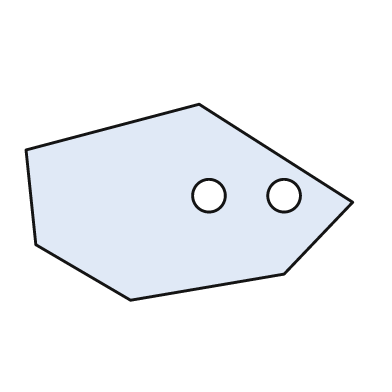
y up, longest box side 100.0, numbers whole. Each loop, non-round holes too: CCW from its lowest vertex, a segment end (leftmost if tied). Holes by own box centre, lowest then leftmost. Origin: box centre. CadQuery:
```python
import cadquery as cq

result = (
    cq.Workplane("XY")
    .moveTo(-18.0, -30.0)
    .lineTo(29.0, -22.0)
    .lineTo(50.0, 0.0)
    .lineTo(3.0, 30.0)
    .lineTo(-50.0, 16.0)
    .lineTo(-47.0, -13.0)
    .close()
    .moveTo(6.0, 2.0)
    .circle(5.0)
    .moveTo(29.0, 2.0)
    .circle(5.0)
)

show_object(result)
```